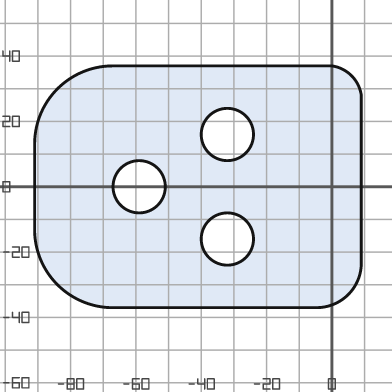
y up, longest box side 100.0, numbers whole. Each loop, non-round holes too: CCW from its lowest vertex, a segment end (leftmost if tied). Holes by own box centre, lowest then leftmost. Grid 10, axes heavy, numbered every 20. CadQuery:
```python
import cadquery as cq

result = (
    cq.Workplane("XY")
    .moveTo(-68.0, -37.0)
    .lineTo(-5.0, -37.0)
    .threePointArc((5.0, -33.0), (9.0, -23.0))
    .lineTo(9.0, 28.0)
    .threePointArc((6.0, 34.0), (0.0, 37.0))
    .lineTo(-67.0, 37.0)
    .threePointArc((-84.0, 30.0), (-91.0, 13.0))
    .lineTo(-91.0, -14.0)
    .threePointArc((-84.0, -30.0), (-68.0, -37.0))
    .close()
    .moveTo(-32.0, -16.0)
    .circle(8.0)
    .moveTo(-59.0, 0.0)
    .circle(8.0)
    .moveTo(-32.0, 16.0)
    .circle(8.0)
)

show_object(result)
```